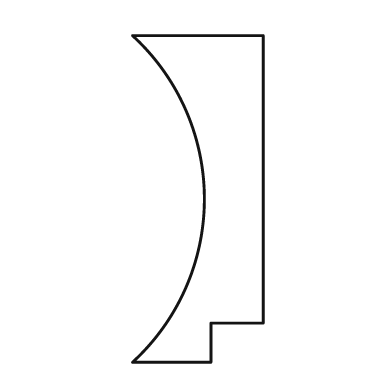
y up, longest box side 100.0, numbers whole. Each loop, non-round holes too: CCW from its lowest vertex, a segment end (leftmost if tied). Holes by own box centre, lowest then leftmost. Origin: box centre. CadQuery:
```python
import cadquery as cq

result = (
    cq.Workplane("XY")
    .moveTo(-20.0, -50.0)
    .lineTo(4.0, -50.0)
    .lineTo(4.0, -38.0)
    .lineTo(20.0, -38.0)
    .lineTo(20.0, 50.0)
    .lineTo(-20.0, 50.0)
    .threePointArc((2.0, 0.0), (-20.0, -50.0))
    .close()
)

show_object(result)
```